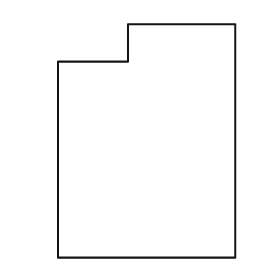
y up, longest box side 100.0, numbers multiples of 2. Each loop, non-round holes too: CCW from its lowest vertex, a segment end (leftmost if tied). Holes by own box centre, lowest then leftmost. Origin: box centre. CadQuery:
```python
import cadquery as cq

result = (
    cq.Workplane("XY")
    .moveTo(-38.0, -50.0)
    .lineTo(38.0, -50.0)
    .lineTo(38.0, 50.0)
    .lineTo(-8.0, 50.0)
    .lineTo(-8.0, 34.0)
    .lineTo(-38.0, 34.0)
    .close()
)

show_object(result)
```